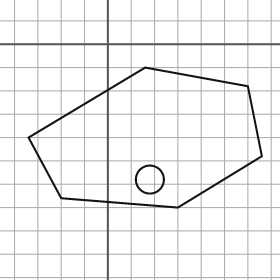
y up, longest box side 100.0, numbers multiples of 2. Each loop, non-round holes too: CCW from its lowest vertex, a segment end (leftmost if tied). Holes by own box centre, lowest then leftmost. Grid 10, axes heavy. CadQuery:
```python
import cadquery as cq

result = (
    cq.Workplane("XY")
    .moveTo(30.0, -70.0)
    .lineTo(66.0, -48.0)
    .lineTo(60.0, -18.0)
    .lineTo(16.0, -10.0)
    .lineTo(-34.0, -40.0)
    .lineTo(-20.0, -66.0)
    .close()
    .moveTo(18.0, -58.0)
    .circle(6.0)
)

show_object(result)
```